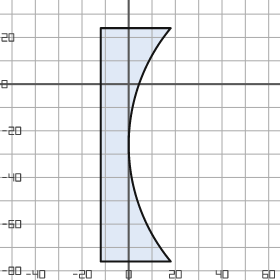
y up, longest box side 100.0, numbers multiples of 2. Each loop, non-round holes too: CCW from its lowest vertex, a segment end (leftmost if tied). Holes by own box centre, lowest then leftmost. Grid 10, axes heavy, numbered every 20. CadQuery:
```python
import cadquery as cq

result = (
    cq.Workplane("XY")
    .moveTo(-12.0, -76.0)
    .lineTo(18.0, -76.0)
    .threePointArc((0.0, -26.0), (18.0, 24.0))
    .lineTo(-12.0, 24.0)
    .close()
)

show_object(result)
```